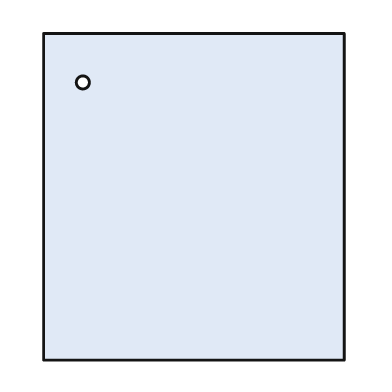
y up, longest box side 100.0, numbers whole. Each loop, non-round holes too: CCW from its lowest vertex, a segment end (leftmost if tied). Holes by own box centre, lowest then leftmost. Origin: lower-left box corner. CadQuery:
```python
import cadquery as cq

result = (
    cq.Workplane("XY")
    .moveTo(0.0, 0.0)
    .lineTo(92.0, 0.0)
    .lineTo(92.0, 100.0)
    .lineTo(0.0, 100.0)
    .close()
    .moveTo(12.0, 85.0)
    .circle(2.0)
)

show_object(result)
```